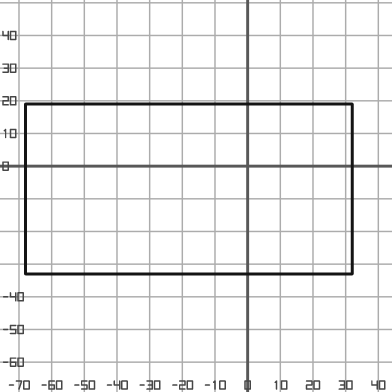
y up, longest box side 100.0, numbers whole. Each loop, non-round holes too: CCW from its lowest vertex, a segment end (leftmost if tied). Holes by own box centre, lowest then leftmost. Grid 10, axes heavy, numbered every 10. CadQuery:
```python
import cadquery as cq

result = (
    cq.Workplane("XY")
    .moveTo(-68.0, -33.0)
    .lineTo(32.0, -33.0)
    .lineTo(32.0, 19.0)
    .lineTo(-68.0, 19.0)
    .close()
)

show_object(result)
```